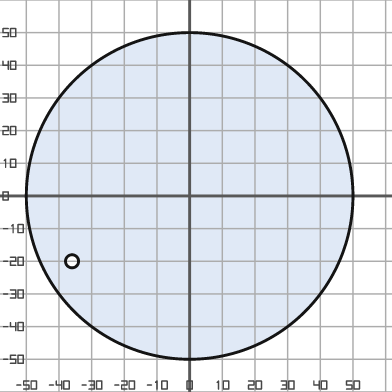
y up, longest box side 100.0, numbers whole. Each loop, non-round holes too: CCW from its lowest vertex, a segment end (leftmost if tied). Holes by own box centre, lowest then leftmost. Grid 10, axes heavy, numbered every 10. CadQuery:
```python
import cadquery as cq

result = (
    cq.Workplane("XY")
    .moveTo(0.0, 0.0)
    .circle(50.0)
    .moveTo(-36.0, -20.0)
    .circle(2.0)
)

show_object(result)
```